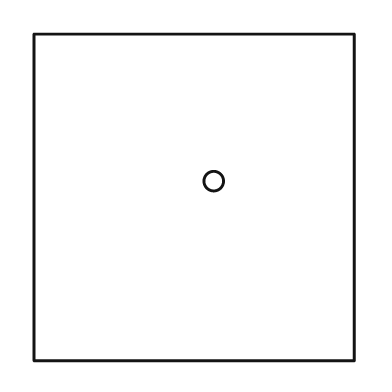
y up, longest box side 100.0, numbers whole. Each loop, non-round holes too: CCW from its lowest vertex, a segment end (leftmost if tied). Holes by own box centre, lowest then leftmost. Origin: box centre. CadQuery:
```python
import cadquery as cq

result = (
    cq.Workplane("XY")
    .moveTo(-49.0, -50.0)
    .lineTo(49.0, -50.0)
    .lineTo(49.0, 50.0)
    .lineTo(-49.0, 50.0)
    .close()
    .moveTo(6.0, 5.0)
    .circle(3.0)
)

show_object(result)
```